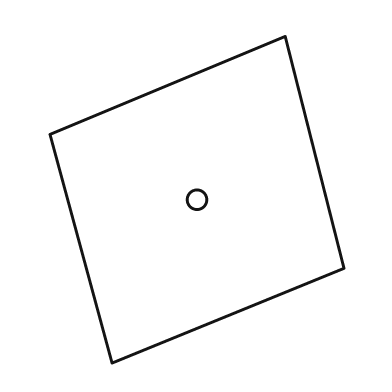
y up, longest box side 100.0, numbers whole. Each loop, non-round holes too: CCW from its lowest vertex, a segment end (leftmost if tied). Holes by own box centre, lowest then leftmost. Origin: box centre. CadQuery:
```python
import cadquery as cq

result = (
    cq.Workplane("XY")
    .moveTo(-26.0, -50.0)
    .lineTo(45.0, -21.0)
    .lineTo(27.0, 50.0)
    .lineTo(-45.0, 20.0)
    .close()
    .moveTo(0.0, 0.0)
    .circle(3.0)
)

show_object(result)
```